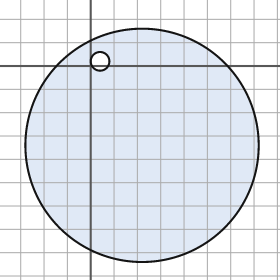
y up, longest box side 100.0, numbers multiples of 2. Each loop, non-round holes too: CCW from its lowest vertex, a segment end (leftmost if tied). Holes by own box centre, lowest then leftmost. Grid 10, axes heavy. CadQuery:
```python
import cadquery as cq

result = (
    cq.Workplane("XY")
    .moveTo(22.0, -34.0)
    .circle(50.0)
    .moveTo(4.0, 2.0)
    .circle(4.0)
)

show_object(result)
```